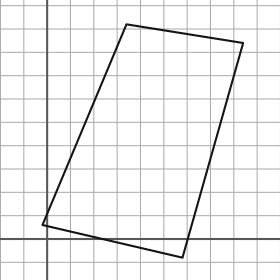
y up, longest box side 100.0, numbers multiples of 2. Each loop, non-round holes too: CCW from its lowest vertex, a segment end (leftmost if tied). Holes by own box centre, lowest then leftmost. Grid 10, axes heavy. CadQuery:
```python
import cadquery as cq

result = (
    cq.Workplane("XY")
    .moveTo(58.0, -8.0)
    .lineTo(84.0, 84.0)
    .lineTo(34.0, 92.0)
    .lineTo(-2.0, 6.0)
    .close()
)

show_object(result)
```